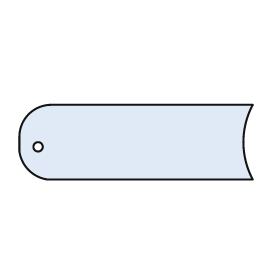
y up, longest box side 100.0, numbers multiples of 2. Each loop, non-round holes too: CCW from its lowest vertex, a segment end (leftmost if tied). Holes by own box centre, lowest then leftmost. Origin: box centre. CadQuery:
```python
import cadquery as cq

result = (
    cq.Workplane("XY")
    .moveTo(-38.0, -16.0)
    .lineTo(50.0, -16.0)
    .threePointArc((46.0, 0.0), (50.0, 16.0))
    .lineTo(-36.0, 16.0)
    .threePointArc((-46.0, 12.0), (-50.0, 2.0))
    .lineTo(-50.0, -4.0)
    .threePointArc((-46.0, -12.0), (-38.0, -16.0))
    .close()
    .moveTo(-42.0, -2.0)
    .circle(2.0)
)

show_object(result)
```